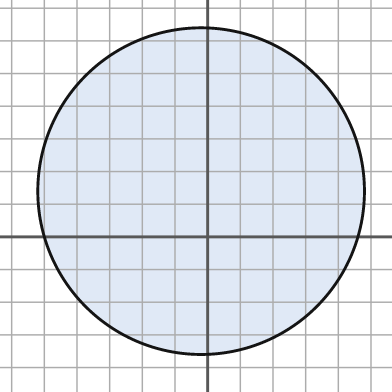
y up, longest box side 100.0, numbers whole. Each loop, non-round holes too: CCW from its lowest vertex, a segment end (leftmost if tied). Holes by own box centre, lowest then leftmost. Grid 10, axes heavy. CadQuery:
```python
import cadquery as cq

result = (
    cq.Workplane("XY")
    .moveTo(-2.0, 14.0)
    .circle(50.0)
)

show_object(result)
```